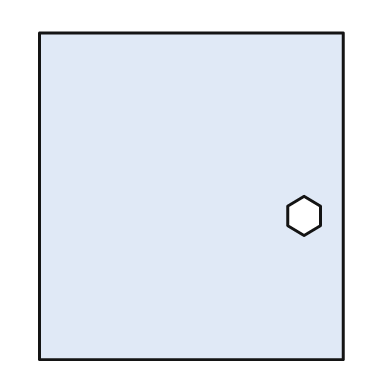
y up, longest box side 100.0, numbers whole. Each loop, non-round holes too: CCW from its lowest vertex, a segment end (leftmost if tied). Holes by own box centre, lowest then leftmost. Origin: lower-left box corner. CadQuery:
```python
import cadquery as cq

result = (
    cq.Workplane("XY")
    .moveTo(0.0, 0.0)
    .lineTo(93.0, 0.0)
    .lineTo(93.0, 100.0)
    .lineTo(0.0, 100.0)
    .close()
    .moveTo(81.0, 38.0)
    .lineTo(86.0, 41.0)
    .lineTo(86.0, 47.0)
    .lineTo(81.0, 50.0)
    .lineTo(76.0, 47.0)
    .lineTo(76.0, 41.0)
    .close()
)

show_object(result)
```